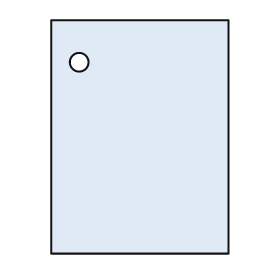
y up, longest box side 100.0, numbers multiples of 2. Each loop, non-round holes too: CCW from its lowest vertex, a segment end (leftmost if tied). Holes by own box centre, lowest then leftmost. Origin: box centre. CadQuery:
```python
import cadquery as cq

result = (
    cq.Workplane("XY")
    .moveTo(-38.0, -50.0)
    .lineTo(38.0, -50.0)
    .lineTo(38.0, 50.0)
    .lineTo(-38.0, 50.0)
    .close()
    .moveTo(-26.0, 32.0)
    .circle(4.0)
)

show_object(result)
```